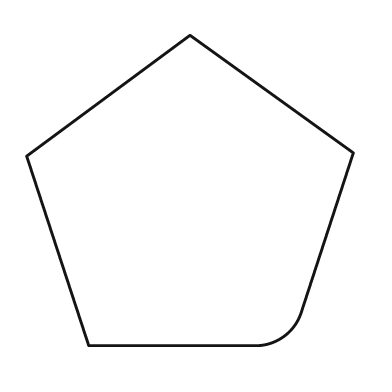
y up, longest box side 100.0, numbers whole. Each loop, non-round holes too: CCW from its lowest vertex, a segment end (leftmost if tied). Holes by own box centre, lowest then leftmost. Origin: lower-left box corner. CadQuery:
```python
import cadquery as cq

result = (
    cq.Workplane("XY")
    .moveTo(19.0, 0.0)
    .lineTo(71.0, 0.0)
    .threePointArc((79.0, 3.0), (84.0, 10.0))
    .lineTo(100.0, 59.0)
    .lineTo(50.0, 95.0)
    .lineTo(0.0, 58.0)
    .close()
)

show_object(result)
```